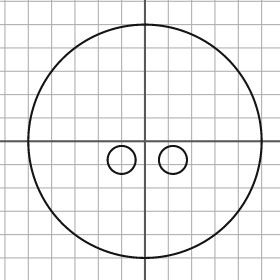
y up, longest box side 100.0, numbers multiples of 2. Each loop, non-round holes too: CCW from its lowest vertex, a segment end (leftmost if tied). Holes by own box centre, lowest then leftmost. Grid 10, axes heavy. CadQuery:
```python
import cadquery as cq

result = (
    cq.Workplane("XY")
    .moveTo(0.0, 0.0)
    .circle(50.0)
    .moveTo(-10.0, -8.0)
    .circle(6.0)
    .moveTo(12.0, -8.0)
    .circle(6.0)
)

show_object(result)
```